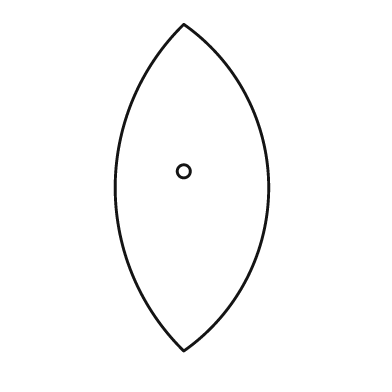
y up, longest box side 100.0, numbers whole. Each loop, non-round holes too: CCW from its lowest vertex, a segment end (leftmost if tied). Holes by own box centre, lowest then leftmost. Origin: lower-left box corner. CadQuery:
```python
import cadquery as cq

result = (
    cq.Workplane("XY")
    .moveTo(21.0, 0.0)
    .threePointArc((47.0, 50.0), (21.0, 100.0))
    .threePointArc((0.0, 50.0), (21.0, 0.0))
    .close()
    .moveTo(21.0, 55.0)
    .circle(2.0)
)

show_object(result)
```